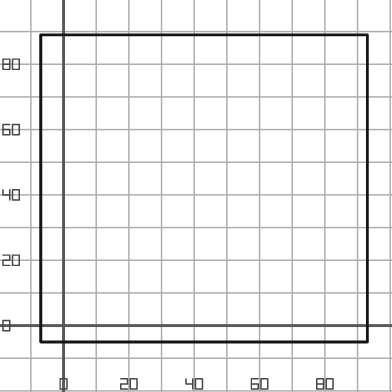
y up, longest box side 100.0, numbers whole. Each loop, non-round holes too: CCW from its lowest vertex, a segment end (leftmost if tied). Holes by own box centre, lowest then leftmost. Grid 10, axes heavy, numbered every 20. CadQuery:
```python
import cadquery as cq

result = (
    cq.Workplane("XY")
    .moveTo(-7.0, -5.0)
    .lineTo(93.0, -5.0)
    .lineTo(93.0, 89.0)
    .lineTo(-7.0, 89.0)
    .close()
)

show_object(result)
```